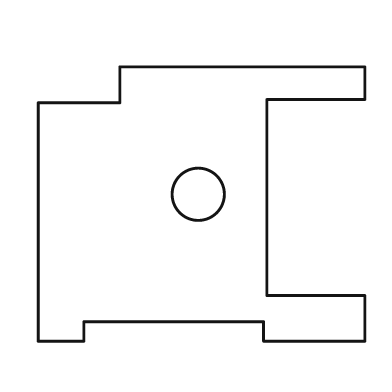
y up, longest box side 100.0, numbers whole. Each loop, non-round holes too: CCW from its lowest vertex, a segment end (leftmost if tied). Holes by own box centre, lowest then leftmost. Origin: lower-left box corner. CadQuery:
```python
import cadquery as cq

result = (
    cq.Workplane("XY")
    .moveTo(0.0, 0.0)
    .lineTo(14.0, 0.0)
    .lineTo(14.0, 6.0)
    .lineTo(69.0, 6.0)
    .lineTo(69.0, 0.0)
    .lineTo(100.0, 0.0)
    .lineTo(100.0, 14.0)
    .lineTo(70.0, 14.0)
    .lineTo(70.0, 74.0)
    .lineTo(100.0, 74.0)
    .lineTo(100.0, 84.0)
    .lineTo(25.0, 84.0)
    .lineTo(25.0, 73.0)
    .lineTo(0.0, 73.0)
    .close()
    .moveTo(49.0, 45.0)
    .circle(8.0)
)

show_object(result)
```